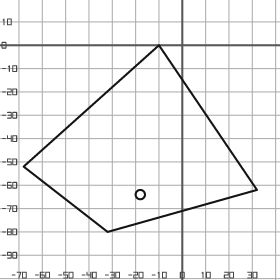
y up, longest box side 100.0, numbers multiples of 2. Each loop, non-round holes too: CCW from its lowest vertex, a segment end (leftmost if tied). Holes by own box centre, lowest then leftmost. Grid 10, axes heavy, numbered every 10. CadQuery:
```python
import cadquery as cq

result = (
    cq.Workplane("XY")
    .moveTo(-32.0, -80.0)
    .lineTo(32.0, -62.0)
    .lineTo(-10.0, 0.0)
    .lineTo(-68.0, -52.0)
    .close()
    .moveTo(-18.0, -64.0)
    .circle(2.0)
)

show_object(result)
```